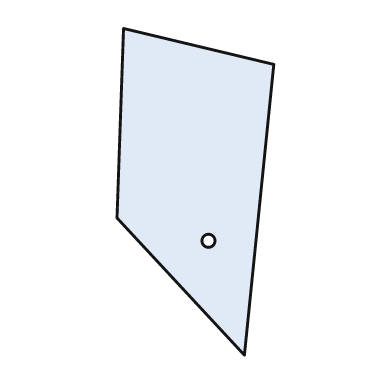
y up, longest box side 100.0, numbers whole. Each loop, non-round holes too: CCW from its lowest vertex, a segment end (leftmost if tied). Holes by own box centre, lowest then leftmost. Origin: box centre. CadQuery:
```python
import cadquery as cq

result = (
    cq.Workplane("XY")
    .moveTo(15.0, -50.0)
    .lineTo(24.0, 39.0)
    .lineTo(-22.0, 50.0)
    .lineTo(-24.0, -8.0)
    .close()
    .moveTo(4.0, -15.0)
    .circle(2.0)
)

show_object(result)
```